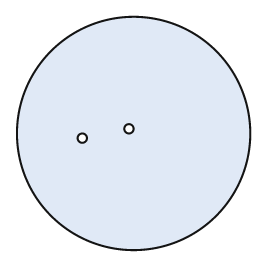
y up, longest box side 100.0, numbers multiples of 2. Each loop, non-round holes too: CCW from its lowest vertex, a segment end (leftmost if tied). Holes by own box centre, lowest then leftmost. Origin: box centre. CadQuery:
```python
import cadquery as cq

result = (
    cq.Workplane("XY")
    .moveTo(0.0, 0.0)
    .circle(50.0)
    .moveTo(-22.0, -2.0)
    .circle(2.0)
    .moveTo(-2.0, 2.0)
    .circle(2.0)
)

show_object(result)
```